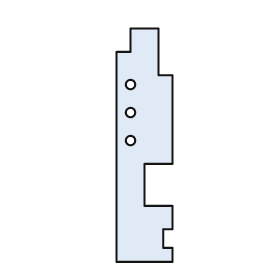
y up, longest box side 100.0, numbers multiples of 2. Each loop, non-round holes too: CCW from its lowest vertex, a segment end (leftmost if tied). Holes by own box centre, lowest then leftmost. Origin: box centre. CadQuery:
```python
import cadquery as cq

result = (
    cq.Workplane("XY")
    .moveTo(-12.0, -50.0)
    .lineTo(12.0, -50.0)
    .lineTo(12.0, -44.0)
    .lineTo(8.0, -44.0)
    .lineTo(8.0, -36.0)
    .lineTo(12.0, -36.0)
    .lineTo(12.0, -26.0)
    .lineTo(0.0, -26.0)
    .lineTo(0.0, -8.0)
    .lineTo(12.0, -8.0)
    .lineTo(12.0, 30.0)
    .lineTo(6.0, 30.0)
    .lineTo(6.0, 50.0)
    .lineTo(-6.0, 50.0)
    .lineTo(-6.0, 40.0)
    .lineTo(-12.0, 40.0)
    .close()
    .moveTo(-6.0, 2.0)
    .circle(2.0)
    .moveTo(-6.0, 14.0)
    .circle(2.0)
    .moveTo(-6.0, 26.0)
    .circle(2.0)
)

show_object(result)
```